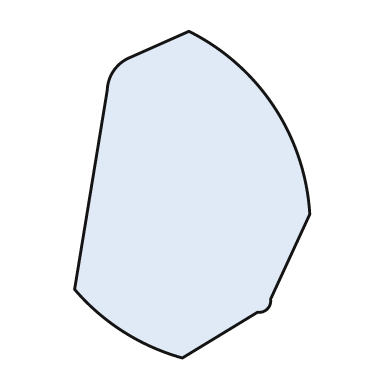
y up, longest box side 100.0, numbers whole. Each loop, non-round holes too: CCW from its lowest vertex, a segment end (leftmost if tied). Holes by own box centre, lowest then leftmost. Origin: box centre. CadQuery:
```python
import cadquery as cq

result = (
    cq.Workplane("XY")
    .moveTo(-3.0, -50.0)
    .lineTo(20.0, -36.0)
    .threePointArc((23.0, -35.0), (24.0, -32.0))
    .lineTo(36.0, -6.0)
    .threePointArc((25.0, 27.0), (-1.0, 50.0))
    .lineTo(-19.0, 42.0)
    .threePointArc((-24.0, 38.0), (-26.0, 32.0))
    .lineTo(-36.0, -29.0)
    .threePointArc((-21.0, -42.0), (-3.0, -50.0))
    .close()
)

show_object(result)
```